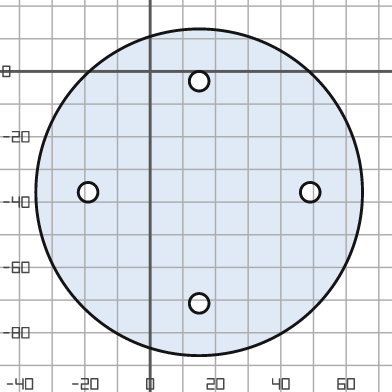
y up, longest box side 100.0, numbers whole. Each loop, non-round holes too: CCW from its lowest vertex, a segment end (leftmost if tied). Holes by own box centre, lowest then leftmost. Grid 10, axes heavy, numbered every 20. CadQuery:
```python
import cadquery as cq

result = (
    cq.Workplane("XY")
    .moveTo(15.0, -37.0)
    .circle(50.0)
    .moveTo(15.0, -71.0)
    .circle(3.0)
    .moveTo(-19.0, -37.0)
    .circle(3.0)
    .moveTo(49.0, -37.0)
    .circle(3.0)
    .moveTo(15.0, -3.0)
    .circle(3.0)
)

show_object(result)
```